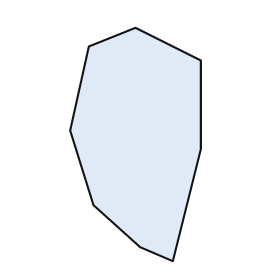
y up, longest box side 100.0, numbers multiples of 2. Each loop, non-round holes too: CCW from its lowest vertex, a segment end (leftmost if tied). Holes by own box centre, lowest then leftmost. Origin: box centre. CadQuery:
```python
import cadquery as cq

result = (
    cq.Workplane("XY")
    .moveTo(16.0, -50.0)
    .lineTo(28.0, -2.0)
    .lineTo(28.0, 36.0)
    .lineTo(0.0, 50.0)
    .lineTo(-20.0, 42.0)
    .lineTo(-28.0, 6.0)
    .lineTo(-18.0, -26.0)
    .lineTo(2.0, -44.0)
    .close()
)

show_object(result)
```